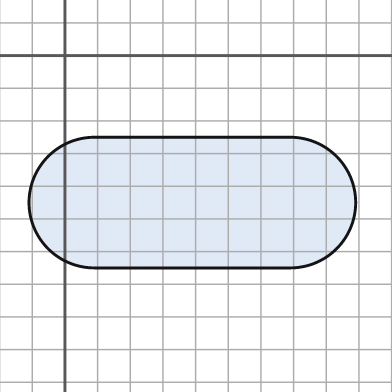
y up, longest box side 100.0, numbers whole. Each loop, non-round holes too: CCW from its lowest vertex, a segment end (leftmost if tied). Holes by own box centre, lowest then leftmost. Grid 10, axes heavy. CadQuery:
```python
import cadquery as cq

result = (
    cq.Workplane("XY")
    .moveTo(9.0, -65.0)
    .lineTo(69.0, -65.0)
    .threePointArc((89.0, -45.0), (69.0, -25.0))
    .lineTo(9.0, -25.0)
    .threePointArc((-11.0, -45.0), (9.0, -65.0))
    .close()
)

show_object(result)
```